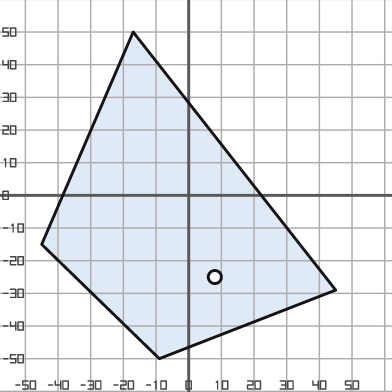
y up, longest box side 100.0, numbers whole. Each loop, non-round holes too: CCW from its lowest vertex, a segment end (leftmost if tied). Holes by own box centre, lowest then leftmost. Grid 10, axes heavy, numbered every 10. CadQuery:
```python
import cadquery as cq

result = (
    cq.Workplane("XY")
    .moveTo(-9.0, -50.0)
    .lineTo(45.0, -29.0)
    .lineTo(-17.0, 50.0)
    .lineTo(-45.0, -15.0)
    .close()
    .moveTo(8.0, -25.0)
    .circle(2.0)
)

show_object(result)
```